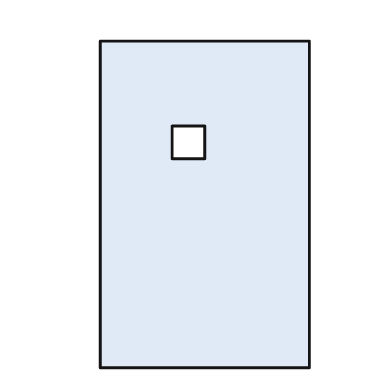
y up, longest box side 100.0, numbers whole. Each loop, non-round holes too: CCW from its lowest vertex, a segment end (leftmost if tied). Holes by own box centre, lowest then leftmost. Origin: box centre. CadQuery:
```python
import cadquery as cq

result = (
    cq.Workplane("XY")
    .moveTo(-32.0, -50.0)
    .lineTo(32.0, -50.0)
    .lineTo(32.0, 50.0)
    .lineTo(-32.0, 50.0)
    .close()
    .moveTo(-10.0, 14.0)
    .lineTo(0.0, 14.0)
    .lineTo(0.0, 24.0)
    .lineTo(-10.0, 24.0)
    .close()
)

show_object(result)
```